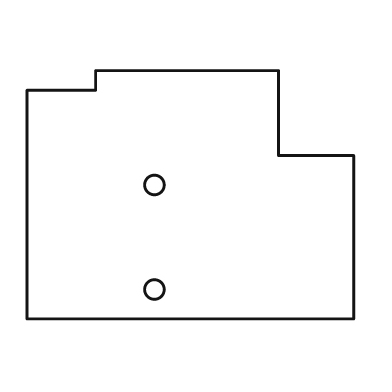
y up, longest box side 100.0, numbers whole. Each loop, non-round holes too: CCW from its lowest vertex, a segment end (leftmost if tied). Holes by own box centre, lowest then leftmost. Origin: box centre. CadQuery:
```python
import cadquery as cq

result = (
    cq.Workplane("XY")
    .moveTo(-50.0, -38.0)
    .lineTo(50.0, -38.0)
    .lineTo(50.0, 12.0)
    .lineTo(27.0, 12.0)
    .lineTo(27.0, 38.0)
    .lineTo(-29.0, 38.0)
    .lineTo(-29.0, 32.0)
    .lineTo(-50.0, 32.0)
    .close()
    .moveTo(-11.0, -29.0)
    .circle(3.0)
    .moveTo(-11.0, 3.0)
    .circle(3.0)
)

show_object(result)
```